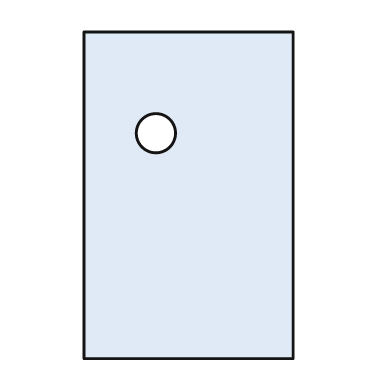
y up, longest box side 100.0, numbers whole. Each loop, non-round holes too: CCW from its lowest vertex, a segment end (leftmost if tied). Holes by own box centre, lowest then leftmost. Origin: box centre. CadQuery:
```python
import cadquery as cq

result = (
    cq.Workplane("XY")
    .moveTo(-32.0, -50.0)
    .lineTo(32.0, -50.0)
    .lineTo(32.0, 50.0)
    .lineTo(-32.0, 50.0)
    .close()
    .moveTo(-10.0, 19.0)
    .circle(6.0)
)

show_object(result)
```